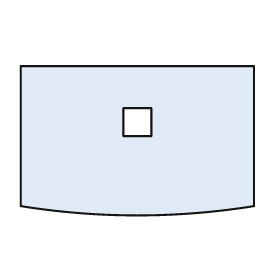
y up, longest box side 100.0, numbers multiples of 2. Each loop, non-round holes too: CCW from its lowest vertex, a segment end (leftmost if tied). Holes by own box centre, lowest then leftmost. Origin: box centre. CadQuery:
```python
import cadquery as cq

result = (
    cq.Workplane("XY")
    .moveTo(-50.0, -28.0)
    .threePointArc((0.0, -32.0), (50.0, -28.0))
    .lineTo(50.0, 32.0)
    .lineTo(-50.0, 32.0)
    .close()
    .moveTo(-6.0, 2.0)
    .lineTo(6.0, 2.0)
    .lineTo(6.0, 14.0)
    .lineTo(-6.0, 14.0)
    .close()
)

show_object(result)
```